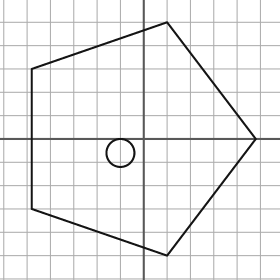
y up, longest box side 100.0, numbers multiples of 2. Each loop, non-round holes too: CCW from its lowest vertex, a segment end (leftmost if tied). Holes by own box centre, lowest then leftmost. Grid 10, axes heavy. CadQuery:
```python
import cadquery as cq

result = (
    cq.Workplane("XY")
    .moveTo(10.0, -50.0)
    .lineTo(48.0, 0.0)
    .lineTo(10.0, 50.0)
    .lineTo(-48.0, 30.0)
    .lineTo(-48.0, -30.0)
    .close()
    .moveTo(-10.0, -6.0)
    .circle(6.0)
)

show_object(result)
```